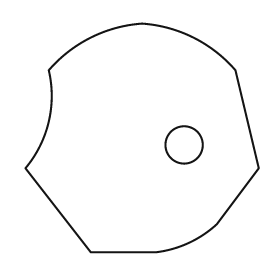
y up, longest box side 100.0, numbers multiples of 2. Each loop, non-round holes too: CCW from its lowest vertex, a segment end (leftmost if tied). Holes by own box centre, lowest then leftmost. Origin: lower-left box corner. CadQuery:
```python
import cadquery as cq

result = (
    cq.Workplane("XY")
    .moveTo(28.0, 0.0)
    .lineTo(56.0, 0.0)
    .threePointArc((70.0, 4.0), (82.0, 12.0))
    .lineTo(100.0, 36.0)
    .lineTo(90.0, 78.0)
    .threePointArc((72.0, 92.0), (50.0, 98.0))
    .threePointArc((28.0, 92.0), (10.0, 78.0))
    .threePointArc((10.0, 56.0), (0.0, 36.0))
    .close()
    .moveTo(68.0, 46.0)
    .circle(8.0)
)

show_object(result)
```